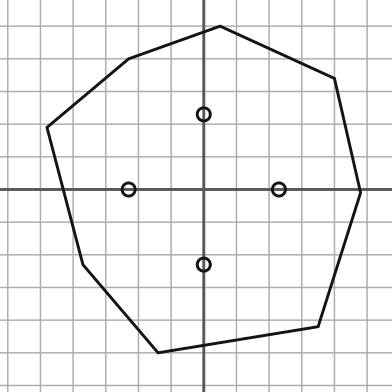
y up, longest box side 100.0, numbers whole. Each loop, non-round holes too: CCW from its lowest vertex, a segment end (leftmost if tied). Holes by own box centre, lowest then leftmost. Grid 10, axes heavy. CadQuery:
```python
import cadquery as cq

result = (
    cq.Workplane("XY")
    .moveTo(-14.0, -50.0)
    .lineTo(35.0, -42.0)
    .lineTo(48.0, -1.0)
    .lineTo(40.0, 34.0)
    .lineTo(5.0, 50.0)
    .lineTo(-23.0, 40.0)
    .lineTo(-48.0, 19.0)
    .lineTo(-37.0, -23.0)
    .close()
    .moveTo(0.0, -23.0)
    .circle(2.0)
    .moveTo(-23.0, 0.0)
    .circle(2.0)
    .moveTo(23.0, 0.0)
    .circle(2.0)
    .moveTo(0.0, 23.0)
    .circle(2.0)
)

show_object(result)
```